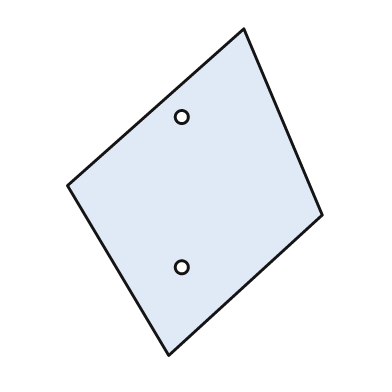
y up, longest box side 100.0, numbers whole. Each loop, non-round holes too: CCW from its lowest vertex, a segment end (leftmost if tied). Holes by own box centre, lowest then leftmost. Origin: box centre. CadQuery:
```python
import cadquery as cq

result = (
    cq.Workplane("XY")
    .moveTo(-8.0, -50.0)
    .lineTo(39.0, -7.0)
    .lineTo(15.0, 50.0)
    .lineTo(-39.0, 2.0)
    .close()
    .moveTo(-4.0, -23.0)
    .circle(2.0)
    .moveTo(-4.0, 23.0)
    .circle(2.0)
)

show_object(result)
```